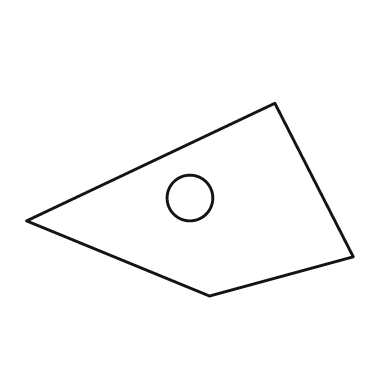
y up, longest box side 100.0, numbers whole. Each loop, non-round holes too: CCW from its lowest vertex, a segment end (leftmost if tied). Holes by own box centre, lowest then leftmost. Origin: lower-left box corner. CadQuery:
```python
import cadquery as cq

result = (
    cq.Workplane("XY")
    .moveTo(56.0, 0.0)
    .lineTo(100.0, 12.0)
    .lineTo(76.0, 59.0)
    .lineTo(0.0, 23.0)
    .close()
    .moveTo(50.0, 30.0)
    .circle(7.0)
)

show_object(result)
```